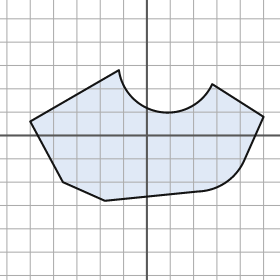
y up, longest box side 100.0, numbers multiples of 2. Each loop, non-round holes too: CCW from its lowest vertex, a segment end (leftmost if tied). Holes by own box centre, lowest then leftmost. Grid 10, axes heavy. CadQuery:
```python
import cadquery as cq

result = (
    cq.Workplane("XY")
    .moveTo(-18.0, -28.0)
    .lineTo(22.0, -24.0)
    .threePointArc((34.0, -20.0), (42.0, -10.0))
    .lineTo(50.0, 8.0)
    .lineTo(28.0, 22.0)
    .threePointArc((6.0, 10.0), (-12.0, 28.0))
    .lineTo(-50.0, 6.0)
    .lineTo(-36.0, -20.0)
    .close()
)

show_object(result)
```